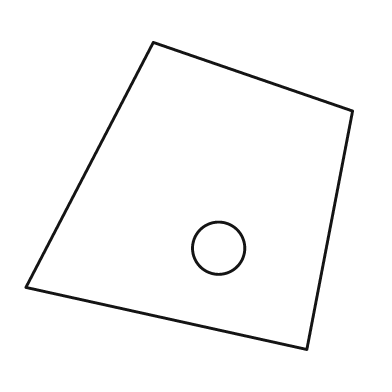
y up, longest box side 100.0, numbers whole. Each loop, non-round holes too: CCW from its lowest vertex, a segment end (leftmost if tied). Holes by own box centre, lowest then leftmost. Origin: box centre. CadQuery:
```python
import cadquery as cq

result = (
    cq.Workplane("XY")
    .moveTo(36.0, -47.0)
    .lineTo(50.0, 26.0)
    .lineTo(-11.0, 47.0)
    .lineTo(-50.0, -28.0)
    .close()
    .moveTo(9.0, -16.0)
    .circle(8.0)
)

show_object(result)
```